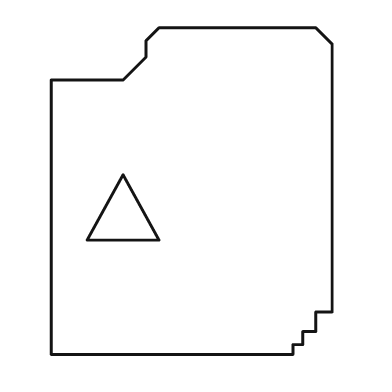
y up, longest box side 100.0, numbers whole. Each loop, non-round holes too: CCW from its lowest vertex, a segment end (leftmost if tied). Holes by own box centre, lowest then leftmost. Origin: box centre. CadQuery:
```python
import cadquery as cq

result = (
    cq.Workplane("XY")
    .moveTo(-43.0, -50.0)
    .lineTo(31.0, -50.0)
    .lineTo(31.0, -47.0)
    .lineTo(34.0, -47.0)
    .lineTo(34.0, -43.0)
    .lineTo(38.0, -43.0)
    .lineTo(38.0, -37.0)
    .lineTo(43.0, -37.0)
    .lineTo(43.0, 45.0)
    .lineTo(38.0, 50.0)
    .lineTo(-10.0, 50.0)
    .lineTo(-14.0, 46.0)
    .lineTo(-14.0, 41.0)
    .lineTo(-21.0, 34.0)
    .lineTo(-43.0, 34.0)
    .close()
    .moveTo(-32.0, -15.0)
    .lineTo(-10.0, -15.0)
    .lineTo(-21.0, 5.0)
    .close()
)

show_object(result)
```